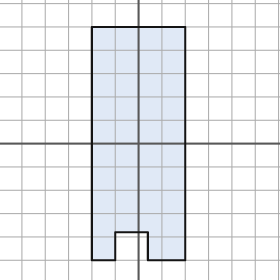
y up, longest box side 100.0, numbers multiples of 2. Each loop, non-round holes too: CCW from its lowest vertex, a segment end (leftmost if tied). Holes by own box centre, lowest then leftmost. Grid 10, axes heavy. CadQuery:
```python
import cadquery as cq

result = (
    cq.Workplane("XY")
    .moveTo(-20.0, -50.0)
    .lineTo(-10.0, -50.0)
    .lineTo(-10.0, -38.0)
    .lineTo(4.0, -38.0)
    .lineTo(4.0, -50.0)
    .lineTo(20.0, -50.0)
    .lineTo(20.0, 50.0)
    .lineTo(-20.0, 50.0)
    .close()
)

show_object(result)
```